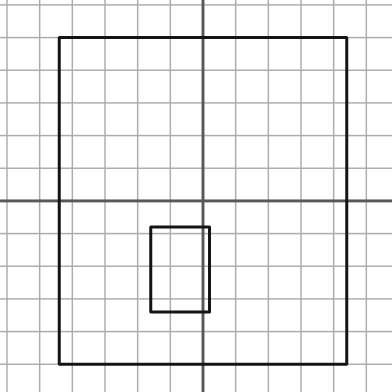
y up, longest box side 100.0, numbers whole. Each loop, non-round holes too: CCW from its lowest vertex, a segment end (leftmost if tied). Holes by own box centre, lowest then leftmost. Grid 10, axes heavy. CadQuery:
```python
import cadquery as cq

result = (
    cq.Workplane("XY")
    .moveTo(-44.0, -50.0)
    .lineTo(44.0, -50.0)
    .lineTo(44.0, 50.0)
    .lineTo(-44.0, 50.0)
    .close()
    .moveTo(-16.0, -34.0)
    .lineTo(2.0, -34.0)
    .lineTo(2.0, -8.0)
    .lineTo(-16.0, -8.0)
    .close()
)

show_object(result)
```